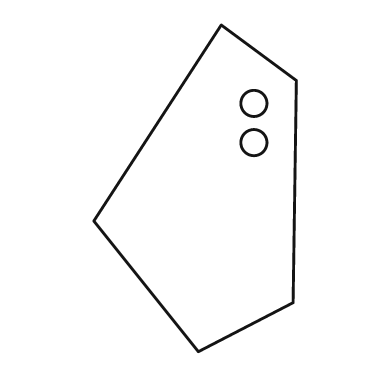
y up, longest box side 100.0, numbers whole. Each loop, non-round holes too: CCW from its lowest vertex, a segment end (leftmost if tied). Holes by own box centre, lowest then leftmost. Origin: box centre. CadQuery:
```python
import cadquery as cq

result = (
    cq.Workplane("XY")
    .moveTo(1.0, -50.0)
    .lineTo(30.0, -35.0)
    .lineTo(31.0, 33.0)
    .lineTo(8.0, 50.0)
    .lineTo(-31.0, -10.0)
    .close()
    .moveTo(18.0, 14.0)
    .circle(4.0)
    .moveTo(18.0, 26.0)
    .circle(4.0)
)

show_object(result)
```